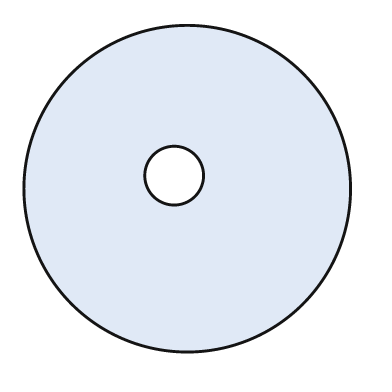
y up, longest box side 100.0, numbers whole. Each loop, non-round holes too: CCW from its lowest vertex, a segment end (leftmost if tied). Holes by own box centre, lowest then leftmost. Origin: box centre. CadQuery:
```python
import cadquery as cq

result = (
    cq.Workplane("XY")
    .moveTo(0.0, 0.0)
    .circle(50.0)
    .moveTo(-4.0, 4.0)
    .circle(9.0)
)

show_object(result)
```